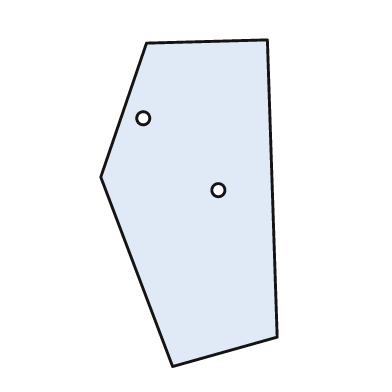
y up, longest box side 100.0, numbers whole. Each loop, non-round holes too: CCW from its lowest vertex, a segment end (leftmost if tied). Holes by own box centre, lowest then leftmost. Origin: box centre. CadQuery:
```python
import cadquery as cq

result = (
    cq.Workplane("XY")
    .moveTo(-5.0, -50.0)
    .lineTo(27.0, -41.0)
    .lineTo(24.0, 50.0)
    .lineTo(-13.0, 49.0)
    .lineTo(-27.0, 8.0)
    .close()
    .moveTo(9.0, 4.0)
    .circle(2.0)
    .moveTo(-14.0, 26.0)
    .circle(2.0)
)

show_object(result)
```